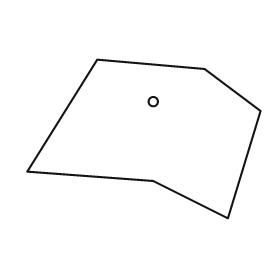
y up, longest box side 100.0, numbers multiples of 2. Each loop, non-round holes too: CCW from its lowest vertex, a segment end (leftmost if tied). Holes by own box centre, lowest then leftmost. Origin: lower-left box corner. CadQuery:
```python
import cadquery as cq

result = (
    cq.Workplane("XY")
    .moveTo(86.0, 0.0)
    .lineTo(100.0, 46.0)
    .lineTo(76.0, 64.0)
    .lineTo(30.0, 68.0)
    .lineTo(0.0, 20.0)
    .lineTo(54.0, 16.0)
    .close()
    .moveTo(54.0, 50.0)
    .circle(2.0)
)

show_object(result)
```